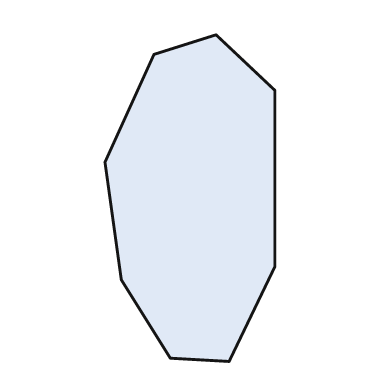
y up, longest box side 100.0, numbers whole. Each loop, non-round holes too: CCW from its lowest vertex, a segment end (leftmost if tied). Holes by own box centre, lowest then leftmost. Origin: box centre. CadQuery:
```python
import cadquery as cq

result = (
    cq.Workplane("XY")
    .moveTo(12.0, -50.0)
    .lineTo(26.0, -21.0)
    .lineTo(26.0, 33.0)
    .lineTo(8.0, 50.0)
    .lineTo(-11.0, 44.0)
    .lineTo(-26.0, 11.0)
    .lineTo(-21.0, -25.0)
    .lineTo(-6.0, -49.0)
    .close()
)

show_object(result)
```